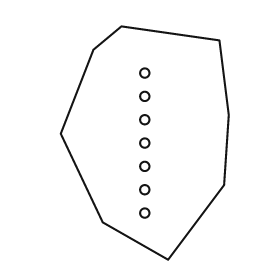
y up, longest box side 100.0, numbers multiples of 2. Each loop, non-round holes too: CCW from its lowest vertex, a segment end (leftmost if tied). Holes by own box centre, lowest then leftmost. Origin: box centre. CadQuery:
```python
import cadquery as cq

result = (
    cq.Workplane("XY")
    .moveTo(10.0, -50.0)
    .lineTo(34.0, -18.0)
    .lineTo(36.0, 12.0)
    .lineTo(32.0, 44.0)
    .lineTo(-10.0, 50.0)
    .lineTo(-22.0, 40.0)
    .lineTo(-36.0, 4.0)
    .lineTo(-18.0, -34.0)
    .close()
    .moveTo(0.0, -30.0)
    .circle(2.0)
    .moveTo(0.0, -20.0)
    .circle(2.0)
    .moveTo(0.0, -10.0)
    .circle(2.0)
    .moveTo(0.0, 0.0)
    .circle(2.0)
    .moveTo(0.0, 10.0)
    .circle(2.0)
    .moveTo(0.0, 20.0)
    .circle(2.0)
    .moveTo(0.0, 30.0)
    .circle(2.0)
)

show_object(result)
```